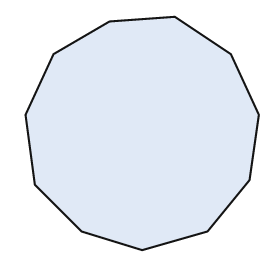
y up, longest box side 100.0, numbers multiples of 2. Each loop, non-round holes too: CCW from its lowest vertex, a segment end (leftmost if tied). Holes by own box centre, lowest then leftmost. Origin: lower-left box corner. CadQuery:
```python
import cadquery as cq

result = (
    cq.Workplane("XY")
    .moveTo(50.0, 0.0)
    .lineTo(78.0, 8.0)
    .lineTo(96.0, 30.0)
    .lineTo(100.0, 58.0)
    .lineTo(88.0, 84.0)
    .lineTo(64.0, 100.0)
    .lineTo(36.0, 98.0)
    .lineTo(12.0, 84.0)
    .lineTo(0.0, 58.0)
    .lineTo(4.0, 28.0)
    .lineTo(24.0, 8.0)
    .close()
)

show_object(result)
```